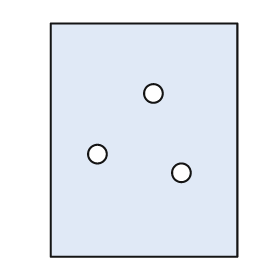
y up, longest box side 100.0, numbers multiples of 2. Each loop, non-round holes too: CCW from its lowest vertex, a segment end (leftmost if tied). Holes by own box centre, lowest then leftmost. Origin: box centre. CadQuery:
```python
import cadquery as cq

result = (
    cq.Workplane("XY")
    .moveTo(-40.0, -50.0)
    .lineTo(40.0, -50.0)
    .lineTo(40.0, 50.0)
    .lineTo(-40.0, 50.0)
    .close()
    .moveTo(16.0, -14.0)
    .circle(4.0)
    .moveTo(-20.0, -6.0)
    .circle(4.0)
    .moveTo(4.0, 20.0)
    .circle(4.0)
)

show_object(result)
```